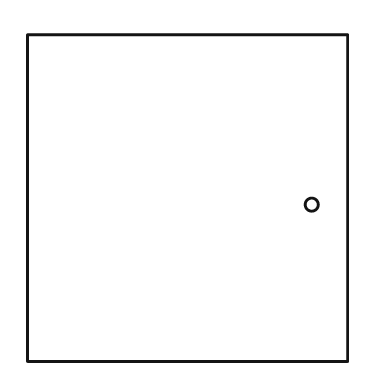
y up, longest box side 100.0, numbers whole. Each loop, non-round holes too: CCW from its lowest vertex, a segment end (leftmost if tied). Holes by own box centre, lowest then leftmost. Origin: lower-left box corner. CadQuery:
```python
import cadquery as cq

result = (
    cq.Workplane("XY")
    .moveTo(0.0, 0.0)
    .lineTo(98.0, 0.0)
    .lineTo(98.0, 100.0)
    .lineTo(0.0, 100.0)
    .close()
    .moveTo(87.0, 48.0)
    .circle(2.0)
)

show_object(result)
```